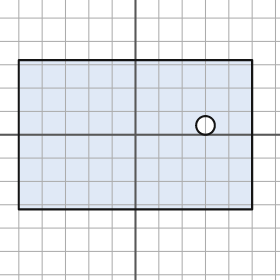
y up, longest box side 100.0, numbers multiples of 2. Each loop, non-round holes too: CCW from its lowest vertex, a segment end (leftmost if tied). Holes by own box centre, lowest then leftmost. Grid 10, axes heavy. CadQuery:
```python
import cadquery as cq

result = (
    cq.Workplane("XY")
    .moveTo(-50.0, -32.0)
    .lineTo(50.0, -32.0)
    .lineTo(50.0, 32.0)
    .lineTo(-50.0, 32.0)
    .close()
    .moveTo(30.0, 4.0)
    .circle(4.0)
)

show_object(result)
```